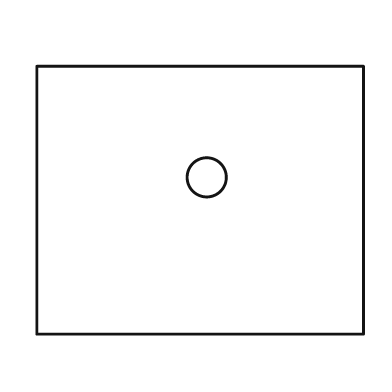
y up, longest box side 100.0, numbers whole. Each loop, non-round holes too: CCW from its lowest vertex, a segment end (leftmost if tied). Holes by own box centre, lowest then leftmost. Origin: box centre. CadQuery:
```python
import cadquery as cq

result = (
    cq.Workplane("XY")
    .moveTo(-50.0, -41.0)
    .lineTo(50.0, -41.0)
    .lineTo(50.0, 41.0)
    .lineTo(-50.0, 41.0)
    .close()
    .moveTo(2.0, 7.0)
    .circle(6.0)
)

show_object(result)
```